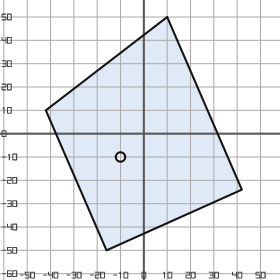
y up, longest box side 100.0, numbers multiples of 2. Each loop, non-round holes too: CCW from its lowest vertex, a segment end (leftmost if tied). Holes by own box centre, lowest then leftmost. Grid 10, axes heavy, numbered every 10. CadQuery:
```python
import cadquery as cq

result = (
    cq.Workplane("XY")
    .moveTo(-16.0, -50.0)
    .lineTo(42.0, -24.0)
    .lineTo(10.0, 50.0)
    .lineTo(-42.0, 10.0)
    .close()
    .moveTo(-10.0, -10.0)
    .circle(2.0)
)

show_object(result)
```